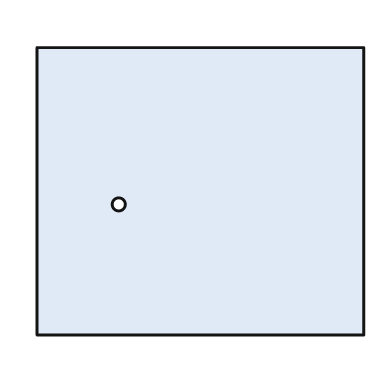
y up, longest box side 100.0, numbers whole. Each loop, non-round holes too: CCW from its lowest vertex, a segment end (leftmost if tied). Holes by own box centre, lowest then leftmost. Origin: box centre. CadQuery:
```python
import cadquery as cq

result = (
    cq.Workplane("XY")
    .moveTo(-50.0, -44.0)
    .lineTo(50.0, -44.0)
    .lineTo(50.0, 44.0)
    .lineTo(-50.0, 44.0)
    .close()
    .moveTo(-25.0, -4.0)
    .circle(2.0)
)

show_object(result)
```